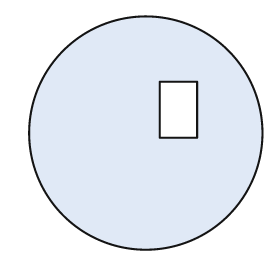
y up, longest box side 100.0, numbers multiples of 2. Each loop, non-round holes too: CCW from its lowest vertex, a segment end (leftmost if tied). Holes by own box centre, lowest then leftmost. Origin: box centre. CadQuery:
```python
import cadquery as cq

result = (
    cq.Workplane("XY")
    .moveTo(0.0, 0.0)
    .circle(50.0)
    .moveTo(6.0, -2.0)
    .lineTo(22.0, -2.0)
    .lineTo(22.0, 22.0)
    .lineTo(6.0, 22.0)
    .close()
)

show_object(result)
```